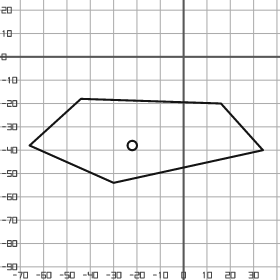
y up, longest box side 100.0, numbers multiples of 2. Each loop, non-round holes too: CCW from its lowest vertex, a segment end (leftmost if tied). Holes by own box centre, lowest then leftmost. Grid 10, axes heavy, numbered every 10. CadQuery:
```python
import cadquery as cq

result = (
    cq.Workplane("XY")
    .moveTo(-30.0, -54.0)
    .lineTo(34.0, -40.0)
    .lineTo(16.0, -20.0)
    .lineTo(-44.0, -18.0)
    .lineTo(-66.0, -38.0)
    .close()
    .moveTo(-22.0, -38.0)
    .circle(2.0)
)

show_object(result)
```